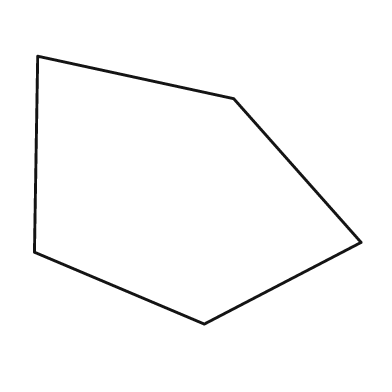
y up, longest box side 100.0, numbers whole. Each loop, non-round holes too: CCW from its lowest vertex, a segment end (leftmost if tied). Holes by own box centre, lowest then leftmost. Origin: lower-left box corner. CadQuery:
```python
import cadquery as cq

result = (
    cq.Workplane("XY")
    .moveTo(52.0, 0.0)
    .lineTo(100.0, 25.0)
    .lineTo(61.0, 69.0)
    .lineTo(1.0, 82.0)
    .lineTo(0.0, 22.0)
    .close()
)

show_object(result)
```